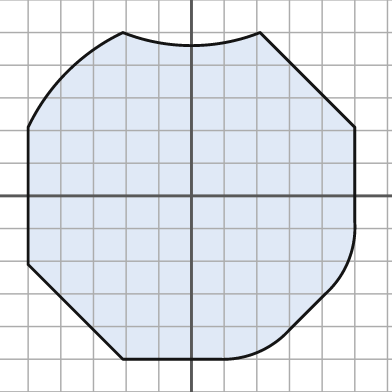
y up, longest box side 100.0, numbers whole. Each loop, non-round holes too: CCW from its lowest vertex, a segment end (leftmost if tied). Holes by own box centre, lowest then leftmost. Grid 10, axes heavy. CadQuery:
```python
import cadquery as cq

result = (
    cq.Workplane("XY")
    .moveTo(-21.0, -50.0)
    .lineTo(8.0, -50.0)
    .threePointArc((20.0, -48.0), (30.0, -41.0))
    .lineTo(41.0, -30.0)
    .threePointArc((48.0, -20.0), (50.0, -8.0))
    .lineTo(50.0, 21.0)
    .lineTo(21.0, 50.0)
    .threePointArc((0.0, 46.0), (-21.0, 50.0))
    .threePointArc((-38.0, 38.0), (-50.0, 21.0))
    .lineTo(-50.0, -21.0)
    .close()
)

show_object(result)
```